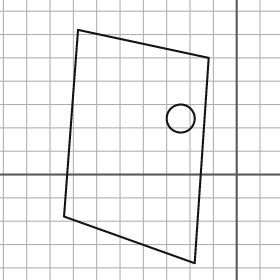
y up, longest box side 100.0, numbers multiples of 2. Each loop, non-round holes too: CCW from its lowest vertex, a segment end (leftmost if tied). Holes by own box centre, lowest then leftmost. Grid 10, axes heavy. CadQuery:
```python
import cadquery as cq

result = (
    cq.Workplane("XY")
    .moveTo(-18.0, -38.0)
    .lineTo(-12.0, 50.0)
    .lineTo(-68.0, 62.0)
    .lineTo(-74.0, -18.0)
    .close()
    .moveTo(-24.0, 24.0)
    .circle(6.0)
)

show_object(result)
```